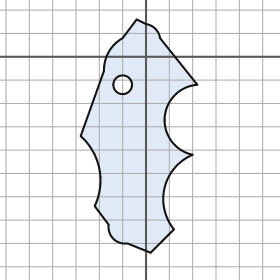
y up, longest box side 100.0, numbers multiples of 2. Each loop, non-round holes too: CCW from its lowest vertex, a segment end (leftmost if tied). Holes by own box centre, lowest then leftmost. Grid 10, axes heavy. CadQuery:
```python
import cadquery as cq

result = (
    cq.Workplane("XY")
    .moveTo(2.0, -84.0)
    .lineTo(12.0, -74.0)
    .threePointArc((8.0, -56.0), (20.0, -42.0))
    .threePointArc((8.0, -26.0), (22.0, -12.0))
    .lineTo(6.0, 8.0)
    .threePointArc((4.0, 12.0), (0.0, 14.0))
    .lineTo(-4.0, 16.0)
    .lineTo(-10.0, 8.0)
    .threePointArc((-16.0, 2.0), (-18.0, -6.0))
    .lineTo(-28.0, -34.0)
    .threePointArc((-20.0, -48.0), (-22.0, -64.0))
    .lineTo(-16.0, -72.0)
    .threePointArc((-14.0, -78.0), (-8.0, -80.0))
    .close()
    .moveTo(-10.0, -12.0)
    .circle(4.0)
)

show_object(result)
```